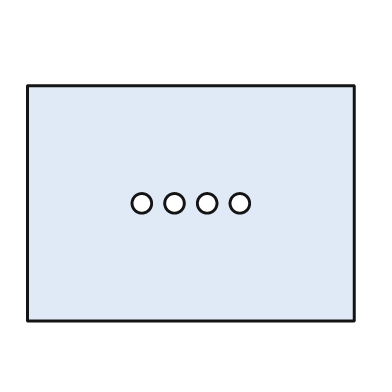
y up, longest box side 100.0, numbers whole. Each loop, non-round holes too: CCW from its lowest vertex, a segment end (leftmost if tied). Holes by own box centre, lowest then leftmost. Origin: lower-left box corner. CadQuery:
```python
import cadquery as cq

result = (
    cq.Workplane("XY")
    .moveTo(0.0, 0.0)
    .lineTo(100.0, 0.0)
    .lineTo(100.0, 72.0)
    .lineTo(0.0, 72.0)
    .close()
    .moveTo(35.0, 36.0)
    .circle(3.0)
    .moveTo(45.0, 36.0)
    .circle(3.0)
    .moveTo(55.0, 36.0)
    .circle(3.0)
    .moveTo(65.0, 36.0)
    .circle(3.0)
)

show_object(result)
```